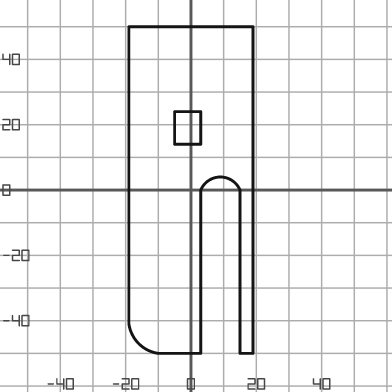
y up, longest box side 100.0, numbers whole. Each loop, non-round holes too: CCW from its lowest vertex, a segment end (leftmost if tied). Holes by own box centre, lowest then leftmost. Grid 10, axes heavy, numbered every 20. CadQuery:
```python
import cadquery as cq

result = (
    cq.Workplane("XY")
    .moveTo(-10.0, -50.0)
    .lineTo(3.0, -50.0)
    .lineTo(3.0, 0.0)
    .threePointArc((9.0, 4.0), (15.0, 0.0))
    .lineTo(15.0, -50.0)
    .lineTo(19.0, -50.0)
    .lineTo(19.0, 50.0)
    .lineTo(-19.0, 50.0)
    .lineTo(-19.0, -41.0)
    .threePointArc((-16.0, -47.0), (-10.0, -50.0))
    .close()
    .moveTo(-5.0, 14.0)
    .lineTo(3.0, 14.0)
    .lineTo(3.0, 24.0)
    .lineTo(-5.0, 24.0)
    .close()
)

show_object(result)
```